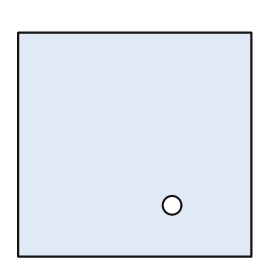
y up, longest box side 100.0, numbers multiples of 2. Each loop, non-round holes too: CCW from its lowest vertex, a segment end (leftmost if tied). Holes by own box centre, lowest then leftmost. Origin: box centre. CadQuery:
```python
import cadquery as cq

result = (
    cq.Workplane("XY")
    .moveTo(-50.0, -48.0)
    .lineTo(50.0, -48.0)
    .lineTo(50.0, 48.0)
    .lineTo(-50.0, 48.0)
    .close()
    .moveTo(16.0, -26.0)
    .circle(4.0)
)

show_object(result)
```